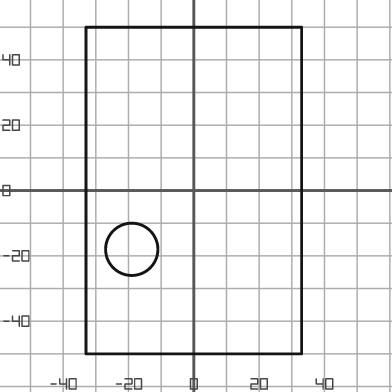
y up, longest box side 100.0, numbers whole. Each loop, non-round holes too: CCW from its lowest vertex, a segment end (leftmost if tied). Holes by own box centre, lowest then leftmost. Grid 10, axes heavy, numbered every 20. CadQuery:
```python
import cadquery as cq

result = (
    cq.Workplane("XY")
    .moveTo(-33.0, -50.0)
    .lineTo(33.0, -50.0)
    .lineTo(33.0, 50.0)
    .lineTo(-33.0, 50.0)
    .close()
    .moveTo(-19.0, -18.0)
    .circle(8.0)
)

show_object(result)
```